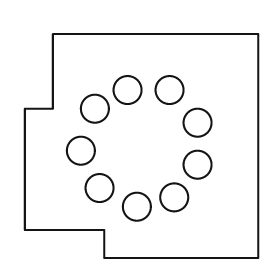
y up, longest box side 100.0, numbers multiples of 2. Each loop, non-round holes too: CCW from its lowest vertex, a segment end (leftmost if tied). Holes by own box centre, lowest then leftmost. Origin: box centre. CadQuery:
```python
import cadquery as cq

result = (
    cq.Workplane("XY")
    .moveTo(-16.0, -48.0)
    .lineTo(50.0, -48.0)
    .lineTo(50.0, 48.0)
    .lineTo(-38.0, 48.0)
    .lineTo(-38.0, 16.0)
    .lineTo(-50.0, 16.0)
    .lineTo(-50.0, -36.0)
    .lineTo(-16.0, -36.0)
    .close()
    .moveTo(-2.0, -26.0)
    .circle(6.0)
    .moveTo(14.0, -22.0)
    .circle(6.0)
    .moveTo(-18.0, -18.0)
    .circle(6.0)
    .moveTo(24.0, -8.0)
    .circle(6.0)
    .moveTo(-26.0, -2.0)
    .circle(6.0)
    .moveTo(24.0, 10.0)
    .circle(6.0)
    .moveTo(-20.0, 16.0)
    .circle(6.0)
    .moveTo(-6.0, 24.0)
    .circle(6.0)
    .moveTo(12.0, 24.0)
    .circle(6.0)
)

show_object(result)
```